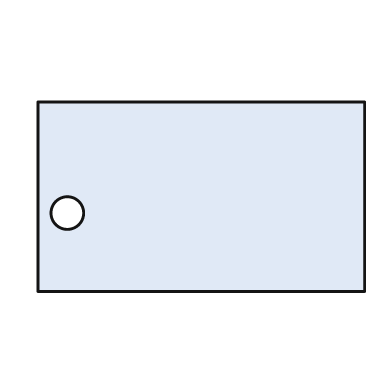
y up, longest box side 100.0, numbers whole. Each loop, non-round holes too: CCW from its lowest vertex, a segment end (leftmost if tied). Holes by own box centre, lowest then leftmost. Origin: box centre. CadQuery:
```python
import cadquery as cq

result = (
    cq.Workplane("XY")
    .moveTo(-50.0, -29.0)
    .lineTo(50.0, -29.0)
    .lineTo(50.0, 29.0)
    .lineTo(-50.0, 29.0)
    .close()
    .moveTo(-41.0, -5.0)
    .circle(5.0)
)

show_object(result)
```